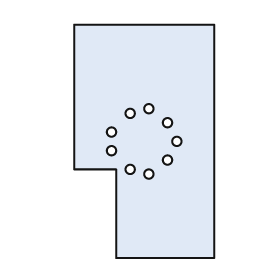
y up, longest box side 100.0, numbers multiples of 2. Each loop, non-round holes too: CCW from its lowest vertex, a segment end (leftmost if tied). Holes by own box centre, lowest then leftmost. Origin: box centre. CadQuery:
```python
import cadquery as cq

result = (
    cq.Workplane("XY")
    .moveTo(-12.0, -50.0)
    .lineTo(30.0, -50.0)
    .lineTo(30.0, 50.0)
    .lineTo(-30.0, 50.0)
    .lineTo(-30.0, -12.0)
    .lineTo(-12.0, -12.0)
    .close()
    .moveTo(2.0, -14.0)
    .circle(2.0)
    .moveTo(-6.0, -12.0)
    .circle(2.0)
    .moveTo(10.0, -8.0)
    .circle(2.0)
    .moveTo(-14.0, -4.0)
    .circle(2.0)
    .moveTo(14.0, 0.0)
    .circle(2.0)
    .moveTo(-14.0, 4.0)
    .circle(2.0)
    .moveTo(10.0, 8.0)
    .circle(2.0)
    .moveTo(-6.0, 12.0)
    .circle(2.0)
    .moveTo(2.0, 14.0)
    .circle(2.0)
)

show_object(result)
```